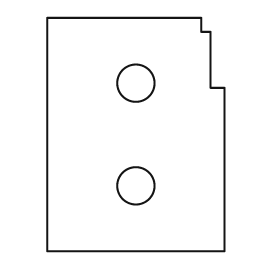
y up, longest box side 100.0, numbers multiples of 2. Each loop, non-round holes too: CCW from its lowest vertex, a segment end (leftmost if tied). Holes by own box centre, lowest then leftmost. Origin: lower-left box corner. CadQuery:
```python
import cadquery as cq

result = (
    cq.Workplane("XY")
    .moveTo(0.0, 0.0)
    .lineTo(76.0, 0.0)
    .lineTo(76.0, 70.0)
    .lineTo(70.0, 70.0)
    .lineTo(70.0, 94.0)
    .lineTo(66.0, 94.0)
    .lineTo(66.0, 100.0)
    .lineTo(0.0, 100.0)
    .close()
    .moveTo(38.0, 28.0)
    .circle(8.0)
    .moveTo(38.0, 72.0)
    .circle(8.0)
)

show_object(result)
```